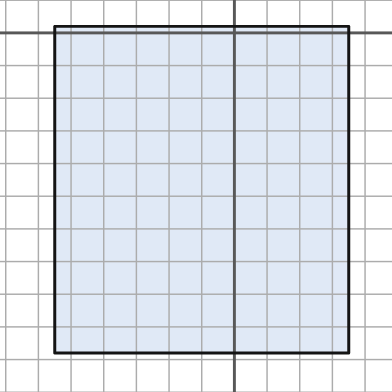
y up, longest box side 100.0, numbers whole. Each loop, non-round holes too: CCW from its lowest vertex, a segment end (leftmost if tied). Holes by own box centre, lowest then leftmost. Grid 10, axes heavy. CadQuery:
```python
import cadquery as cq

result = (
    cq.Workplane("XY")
    .moveTo(-55.0, -98.0)
    .lineTo(35.0, -98.0)
    .lineTo(35.0, 2.0)
    .lineTo(-55.0, 2.0)
    .close()
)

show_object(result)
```